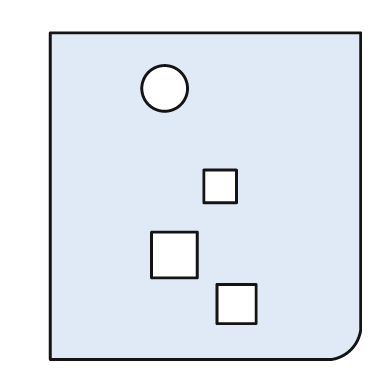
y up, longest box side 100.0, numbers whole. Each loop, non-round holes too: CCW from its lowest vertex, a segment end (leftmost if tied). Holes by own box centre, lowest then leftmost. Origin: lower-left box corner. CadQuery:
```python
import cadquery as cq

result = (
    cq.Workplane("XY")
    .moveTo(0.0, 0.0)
    .lineTo(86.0, 0.0)
    .threePointArc((92.0, 3.0), (95.0, 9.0))
    .lineTo(95.0, 100.0)
    .lineTo(0.0, 100.0)
    .close()
    .moveTo(51.0, 11.0)
    .lineTo(63.0, 11.0)
    .lineTo(63.0, 23.0)
    .lineTo(51.0, 23.0)
    .close()
    .moveTo(31.0, 25.0)
    .lineTo(45.0, 25.0)
    .lineTo(45.0, 39.0)
    .lineTo(31.0, 39.0)
    .close()
    .moveTo(47.0, 48.0)
    .lineTo(57.0, 48.0)
    .lineTo(57.0, 58.0)
    .lineTo(47.0, 58.0)
    .close()
    .moveTo(35.0, 83.0)
    .circle(7.0)
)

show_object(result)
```